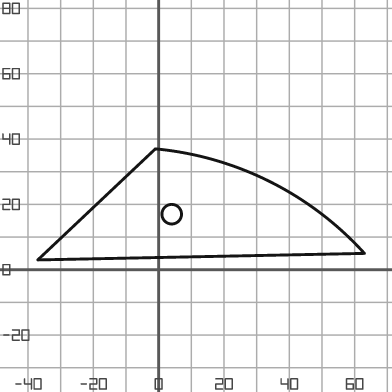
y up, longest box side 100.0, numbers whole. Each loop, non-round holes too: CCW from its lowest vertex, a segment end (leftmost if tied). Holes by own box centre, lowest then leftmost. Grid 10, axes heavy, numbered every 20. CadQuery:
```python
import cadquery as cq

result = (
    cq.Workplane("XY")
    .moveTo(-37.0, 3.0)
    .lineTo(63.0, 5.0)
    .threePointArc((34.0, 27.0), (-1.0, 37.0))
    .close()
    .moveTo(4.0, 17.0)
    .circle(3.0)
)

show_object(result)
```